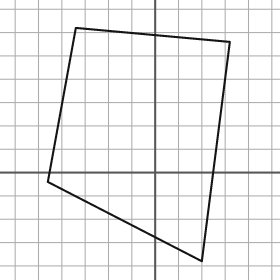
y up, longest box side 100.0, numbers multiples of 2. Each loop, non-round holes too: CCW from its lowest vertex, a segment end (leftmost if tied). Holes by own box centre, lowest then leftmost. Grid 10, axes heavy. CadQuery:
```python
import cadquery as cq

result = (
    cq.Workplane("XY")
    .moveTo(20.0, -38.0)
    .lineTo(32.0, 56.0)
    .lineTo(-34.0, 62.0)
    .lineTo(-46.0, -4.0)
    .close()
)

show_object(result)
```